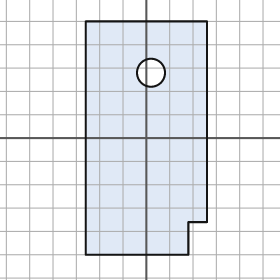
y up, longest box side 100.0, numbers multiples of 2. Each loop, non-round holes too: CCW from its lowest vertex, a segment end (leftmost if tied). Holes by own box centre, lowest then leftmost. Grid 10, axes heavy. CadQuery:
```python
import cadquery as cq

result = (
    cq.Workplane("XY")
    .moveTo(-26.0, -50.0)
    .lineTo(18.0, -50.0)
    .lineTo(18.0, -36.0)
    .lineTo(26.0, -36.0)
    .lineTo(26.0, 50.0)
    .lineTo(-26.0, 50.0)
    .close()
    .moveTo(2.0, 28.0)
    .circle(6.0)
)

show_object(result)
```